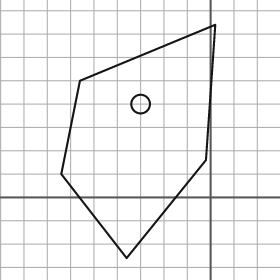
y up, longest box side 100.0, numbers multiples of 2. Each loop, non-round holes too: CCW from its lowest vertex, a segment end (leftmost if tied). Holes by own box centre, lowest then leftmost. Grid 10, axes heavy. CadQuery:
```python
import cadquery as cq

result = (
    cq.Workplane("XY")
    .moveTo(-36.0, -26.0)
    .lineTo(-2.0, 16.0)
    .lineTo(2.0, 74.0)
    .lineTo(-56.0, 50.0)
    .lineTo(-64.0, 10.0)
    .close()
    .moveTo(-30.0, 40.0)
    .circle(4.0)
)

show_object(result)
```